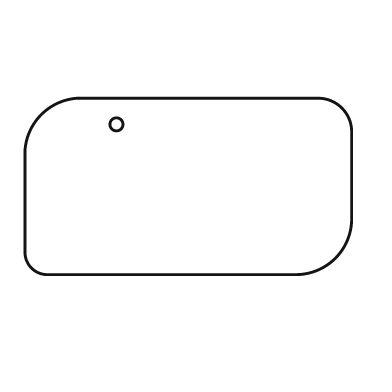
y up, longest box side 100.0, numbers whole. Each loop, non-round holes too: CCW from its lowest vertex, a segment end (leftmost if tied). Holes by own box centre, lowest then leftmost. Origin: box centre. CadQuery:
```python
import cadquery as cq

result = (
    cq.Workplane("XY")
    .moveTo(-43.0, -27.0)
    .lineTo(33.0, -27.0)
    .threePointArc((45.0, -22.0), (50.0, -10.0))
    .lineTo(50.0, 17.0)
    .threePointArc((47.0, 24.0), (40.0, 27.0))
    .lineTo(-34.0, 27.0)
    .threePointArc((-45.0, 22.0), (-50.0, 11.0))
    .lineTo(-50.0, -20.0)
    .threePointArc((-48.0, -25.0), (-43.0, -27.0))
    .close()
    .moveTo(-22.0, 19.0)
    .circle(2.0)
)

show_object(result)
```